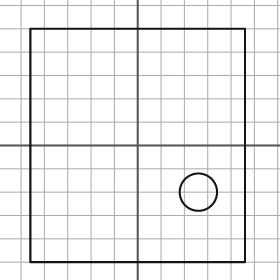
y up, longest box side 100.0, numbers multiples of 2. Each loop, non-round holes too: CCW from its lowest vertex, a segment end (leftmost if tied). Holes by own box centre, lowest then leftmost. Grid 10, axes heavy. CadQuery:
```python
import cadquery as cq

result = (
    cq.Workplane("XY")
    .moveTo(-46.0, -50.0)
    .lineTo(46.0, -50.0)
    .lineTo(46.0, 50.0)
    .lineTo(-46.0, 50.0)
    .close()
    .moveTo(26.0, -20.0)
    .circle(8.0)
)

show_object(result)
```